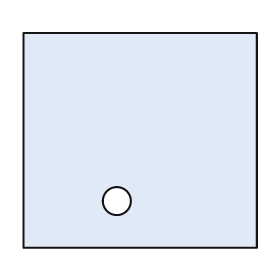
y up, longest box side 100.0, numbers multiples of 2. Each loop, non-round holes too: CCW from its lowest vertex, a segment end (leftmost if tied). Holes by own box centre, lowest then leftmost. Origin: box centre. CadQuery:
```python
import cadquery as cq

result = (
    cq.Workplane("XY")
    .moveTo(-50.0, -46.0)
    .lineTo(50.0, -46.0)
    .lineTo(50.0, 46.0)
    .lineTo(-50.0, 46.0)
    .close()
    .moveTo(-10.0, -26.0)
    .circle(6.0)
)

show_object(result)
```